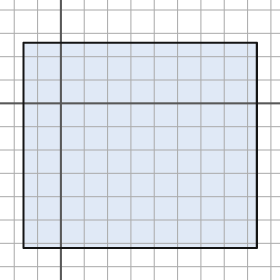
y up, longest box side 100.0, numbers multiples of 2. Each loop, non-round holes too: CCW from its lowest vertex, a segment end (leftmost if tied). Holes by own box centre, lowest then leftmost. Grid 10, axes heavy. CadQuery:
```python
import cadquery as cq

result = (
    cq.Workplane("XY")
    .moveTo(-16.0, -62.0)
    .lineTo(84.0, -62.0)
    .lineTo(84.0, 26.0)
    .lineTo(-16.0, 26.0)
    .close()
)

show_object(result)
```